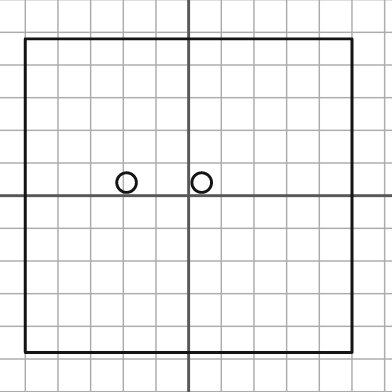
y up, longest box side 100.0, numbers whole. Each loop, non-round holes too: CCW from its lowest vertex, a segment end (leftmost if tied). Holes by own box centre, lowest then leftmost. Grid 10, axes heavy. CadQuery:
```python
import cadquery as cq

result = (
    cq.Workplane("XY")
    .moveTo(-50.0, -48.0)
    .lineTo(50.0, -48.0)
    .lineTo(50.0, 48.0)
    .lineTo(-50.0, 48.0)
    .close()
    .moveTo(-19.0, 4.0)
    .circle(3.0)
    .moveTo(4.0, 4.0)
    .circle(3.0)
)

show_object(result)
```